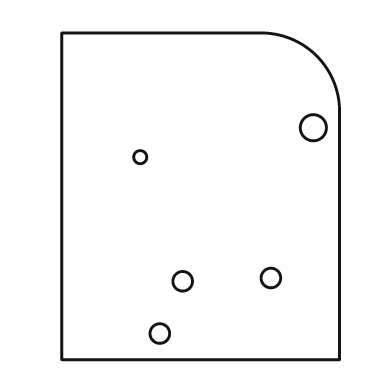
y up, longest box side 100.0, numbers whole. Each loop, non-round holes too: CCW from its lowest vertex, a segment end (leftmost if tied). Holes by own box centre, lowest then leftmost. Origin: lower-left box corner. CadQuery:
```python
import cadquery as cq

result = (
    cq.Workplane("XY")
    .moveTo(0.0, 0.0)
    .lineTo(85.0, 0.0)
    .lineTo(85.0, 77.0)
    .threePointArc((78.0, 93.0), (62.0, 100.0))
    .lineTo(0.0, 100.0)
    .close()
    .moveTo(30.0, 8.0)
    .circle(3.0)
    .moveTo(37.0, 24.0)
    .circle(3.0)
    .moveTo(64.0, 25.0)
    .circle(3.0)
    .moveTo(24.0, 62.0)
    .circle(2.0)
    .moveTo(77.0, 71.0)
    .circle(4.0)
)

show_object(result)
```